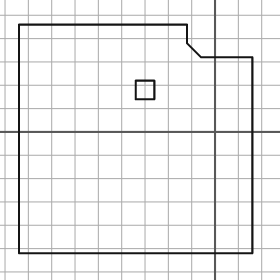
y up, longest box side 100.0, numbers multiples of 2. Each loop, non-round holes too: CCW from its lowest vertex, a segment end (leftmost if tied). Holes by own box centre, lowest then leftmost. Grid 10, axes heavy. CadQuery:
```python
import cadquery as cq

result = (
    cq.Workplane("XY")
    .moveTo(-84.0, -52.0)
    .lineTo(16.0, -52.0)
    .lineTo(16.0, 32.0)
    .lineTo(-6.0, 32.0)
    .lineTo(-12.0, 38.0)
    .lineTo(-12.0, 46.0)
    .lineTo(-84.0, 46.0)
    .close()
    .moveTo(-34.0, 14.0)
    .lineTo(-26.0, 14.0)
    .lineTo(-26.0, 22.0)
    .lineTo(-34.0, 22.0)
    .close()
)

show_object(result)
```